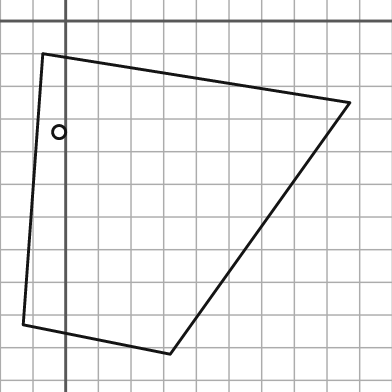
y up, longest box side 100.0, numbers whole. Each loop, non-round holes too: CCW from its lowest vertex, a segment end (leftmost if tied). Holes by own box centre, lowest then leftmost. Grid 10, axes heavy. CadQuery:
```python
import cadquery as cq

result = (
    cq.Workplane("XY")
    .moveTo(32.0, -102.0)
    .lineTo(87.0, -25.0)
    .lineTo(-7.0, -10.0)
    .lineTo(-13.0, -93.0)
    .close()
    .moveTo(-2.0, -34.0)
    .circle(2.0)
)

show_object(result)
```